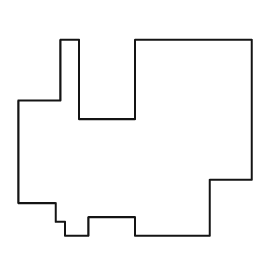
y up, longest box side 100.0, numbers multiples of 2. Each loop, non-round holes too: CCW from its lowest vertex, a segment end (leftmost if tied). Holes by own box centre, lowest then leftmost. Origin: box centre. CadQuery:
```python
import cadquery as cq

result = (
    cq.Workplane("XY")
    .moveTo(-30.0, -42.0)
    .lineTo(-20.0, -42.0)
    .lineTo(-20.0, -34.0)
    .lineTo(0.0, -34.0)
    .lineTo(0.0, -42.0)
    .lineTo(32.0, -42.0)
    .lineTo(32.0, -18.0)
    .lineTo(50.0, -18.0)
    .lineTo(50.0, 42.0)
    .lineTo(0.0, 42.0)
    .lineTo(0.0, 8.0)
    .lineTo(-24.0, 8.0)
    .lineTo(-24.0, 42.0)
    .lineTo(-32.0, 42.0)
    .lineTo(-32.0, 16.0)
    .lineTo(-50.0, 16.0)
    .lineTo(-50.0, -28.0)
    .lineTo(-34.0, -28.0)
    .lineTo(-34.0, -36.0)
    .lineTo(-30.0, -36.0)
    .close()
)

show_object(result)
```